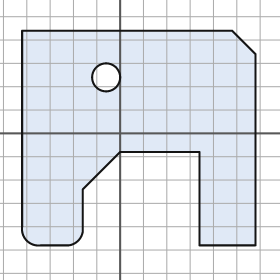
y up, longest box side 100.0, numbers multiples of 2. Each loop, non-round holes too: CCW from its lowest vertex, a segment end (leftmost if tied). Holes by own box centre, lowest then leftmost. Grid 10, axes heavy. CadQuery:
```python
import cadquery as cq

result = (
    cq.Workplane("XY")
    .moveTo(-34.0, -48.0)
    .lineTo(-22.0, -48.0)
    .threePointArc((-18.0, -46.0), (-16.0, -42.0))
    .lineTo(-16.0, -24.0)
    .lineTo(0.0, -8.0)
    .lineTo(34.0, -8.0)
    .lineTo(34.0, -48.0)
    .lineTo(58.0, -48.0)
    .lineTo(58.0, 34.0)
    .lineTo(48.0, 44.0)
    .lineTo(-42.0, 44.0)
    .lineTo(-42.0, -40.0)
    .threePointArc((-40.0, -46.0), (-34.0, -48.0))
    .close()
    .moveTo(-6.0, 24.0)
    .circle(6.0)
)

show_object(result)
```